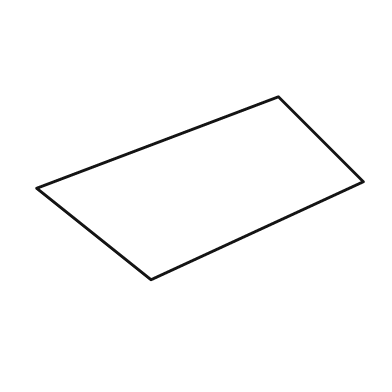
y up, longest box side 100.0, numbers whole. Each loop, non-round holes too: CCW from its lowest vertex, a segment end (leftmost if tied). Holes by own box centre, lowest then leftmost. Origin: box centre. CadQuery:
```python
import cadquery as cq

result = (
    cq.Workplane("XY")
    .moveTo(-15.0, -28.0)
    .lineTo(50.0, 2.0)
    .lineTo(24.0, 28.0)
    .lineTo(-50.0, 0.0)
    .close()
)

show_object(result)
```